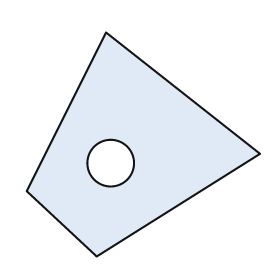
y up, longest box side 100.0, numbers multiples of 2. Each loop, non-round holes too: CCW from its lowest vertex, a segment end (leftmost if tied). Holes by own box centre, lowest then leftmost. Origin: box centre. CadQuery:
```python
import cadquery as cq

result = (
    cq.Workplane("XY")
    .moveTo(-20.0, -48.0)
    .lineTo(50.0, -4.0)
    .lineTo(-16.0, 48.0)
    .lineTo(-50.0, -20.0)
    .close()
    .moveTo(-14.0, -8.0)
    .circle(10.0)
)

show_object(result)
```